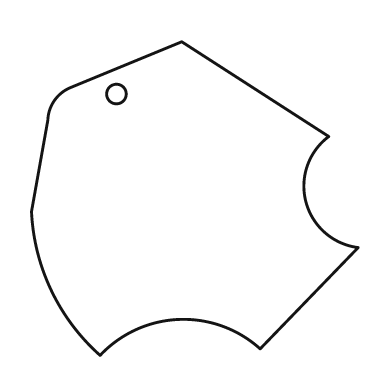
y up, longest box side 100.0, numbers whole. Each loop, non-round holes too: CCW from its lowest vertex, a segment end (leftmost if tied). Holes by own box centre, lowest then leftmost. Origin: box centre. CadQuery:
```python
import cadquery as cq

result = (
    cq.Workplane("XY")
    .moveTo(-29.0, -48.0)
    .threePointArc((-5.0, -37.0), (20.0, -46.0))
    .lineTo(50.0, -15.0)
    .threePointArc((34.0, -1.0), (41.0, 19.0))
    .lineTo(-4.0, 48.0)
    .lineTo(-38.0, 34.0)
    .threePointArc((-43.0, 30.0), (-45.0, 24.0))
    .lineTo(-50.0, -4.0)
    .threePointArc((-44.0, -28.0), (-29.0, -48.0))
    .close()
    .moveTo(-24.0, 32.0)
    .circle(3.0)
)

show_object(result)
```